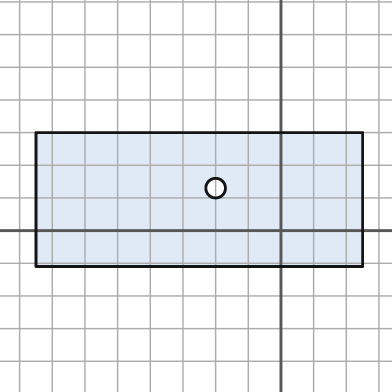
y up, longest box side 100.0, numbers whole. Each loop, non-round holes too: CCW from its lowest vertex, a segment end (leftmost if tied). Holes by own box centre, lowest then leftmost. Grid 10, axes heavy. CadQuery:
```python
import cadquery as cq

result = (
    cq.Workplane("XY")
    .moveTo(-75.0, -11.0)
    .lineTo(25.0, -11.0)
    .lineTo(25.0, 30.0)
    .lineTo(-75.0, 30.0)
    .close()
    .moveTo(-20.0, 13.0)
    .circle(3.0)
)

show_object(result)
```